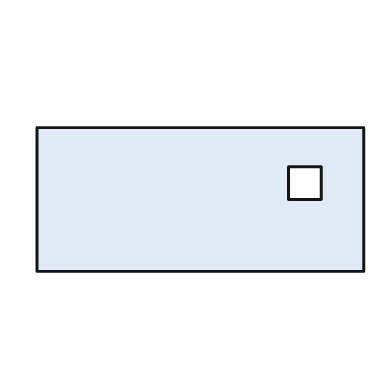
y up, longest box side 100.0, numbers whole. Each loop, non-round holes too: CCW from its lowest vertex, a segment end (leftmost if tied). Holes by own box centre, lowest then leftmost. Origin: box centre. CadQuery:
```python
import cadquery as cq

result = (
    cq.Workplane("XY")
    .moveTo(-50.0, -22.0)
    .lineTo(50.0, -22.0)
    .lineTo(50.0, 22.0)
    .lineTo(-50.0, 22.0)
    .close()
    .moveTo(27.0, 0.0)
    .lineTo(37.0, 0.0)
    .lineTo(37.0, 10.0)
    .lineTo(27.0, 10.0)
    .close()
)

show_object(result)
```